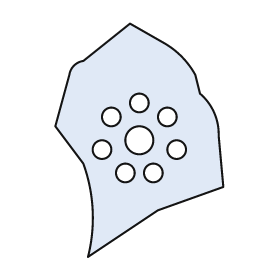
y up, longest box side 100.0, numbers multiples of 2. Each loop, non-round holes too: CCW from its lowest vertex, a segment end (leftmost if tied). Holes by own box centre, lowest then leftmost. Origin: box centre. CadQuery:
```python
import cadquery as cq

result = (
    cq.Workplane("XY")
    .moveTo(-22.0, -50.0)
    .lineTo(8.0, -30.0)
    .lineTo(36.0, -20.0)
    .lineTo(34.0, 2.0)
    .threePointArc((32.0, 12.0), (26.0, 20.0))
    .lineTo(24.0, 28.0)
    .threePointArc((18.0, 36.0), (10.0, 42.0))
    .lineTo(-4.0, 50.0)
    .lineTo(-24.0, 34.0)
    .threePointArc((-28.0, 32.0), (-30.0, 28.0))
    .lineTo(-36.0, 6.0)
    .lineTo(-24.0, -10.0)
    .threePointArc((-20.0, -30.0), (-22.0, -50.0))
    .close()
    .moveTo(-6.0, -14.0)
    .circle(4.0)
    .moveTo(6.0, -14.0)
    .circle(4.0)
    .moveTo(-16.0, -4.0)
    .circle(4.0)
    .moveTo(16.0, -4.0)
    .circle(4.0)
    .moveTo(0.0, 0.0)
    .circle(6.0)
    .moveTo(-12.0, 10.0)
    .circle(4.0)
    .moveTo(12.0, 10.0)
    .circle(4.0)
    .moveTo(0.0, 16.0)
    .circle(4.0)
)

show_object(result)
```